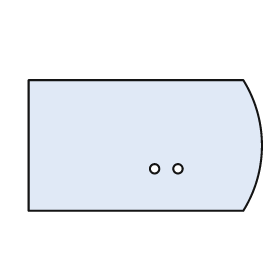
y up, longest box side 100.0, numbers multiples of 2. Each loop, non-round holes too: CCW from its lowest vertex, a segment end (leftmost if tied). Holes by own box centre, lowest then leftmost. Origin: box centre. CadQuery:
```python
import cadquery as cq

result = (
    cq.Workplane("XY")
    .moveTo(-50.0, -28.0)
    .lineTo(42.0, -28.0)
    .threePointArc((50.0, 0.0), (42.0, 28.0))
    .lineTo(-50.0, 28.0)
    .close()
    .moveTo(4.0, -10.0)
    .circle(2.0)
    .moveTo(14.0, -10.0)
    .circle(2.0)
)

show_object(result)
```